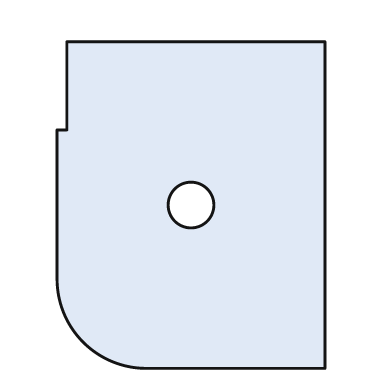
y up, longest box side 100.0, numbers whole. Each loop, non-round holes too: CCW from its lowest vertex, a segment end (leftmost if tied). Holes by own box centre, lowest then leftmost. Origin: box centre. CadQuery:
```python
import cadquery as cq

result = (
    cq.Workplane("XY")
    .moveTo(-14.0, -50.0)
    .lineTo(41.0, -50.0)
    .lineTo(41.0, 50.0)
    .lineTo(-38.0, 50.0)
    .lineTo(-38.0, 23.0)
    .lineTo(-41.0, 23.0)
    .lineTo(-41.0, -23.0)
    .threePointArc((-33.0, -42.0), (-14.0, -50.0))
    .close()
    .moveTo(0.0, 0.0)
    .circle(7.0)
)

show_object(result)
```